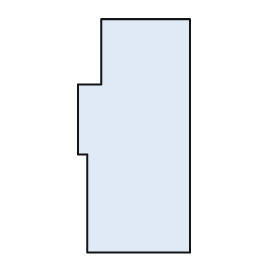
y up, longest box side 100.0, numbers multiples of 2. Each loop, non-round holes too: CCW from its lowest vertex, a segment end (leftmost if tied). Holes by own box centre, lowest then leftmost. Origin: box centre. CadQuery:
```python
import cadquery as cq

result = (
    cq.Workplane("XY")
    .moveTo(-20.0, -50.0)
    .lineTo(24.0, -50.0)
    .lineTo(24.0, 50.0)
    .lineTo(-14.0, 50.0)
    .lineTo(-14.0, 22.0)
    .lineTo(-24.0, 22.0)
    .lineTo(-24.0, -8.0)
    .lineTo(-20.0, -8.0)
    .close()
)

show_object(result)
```